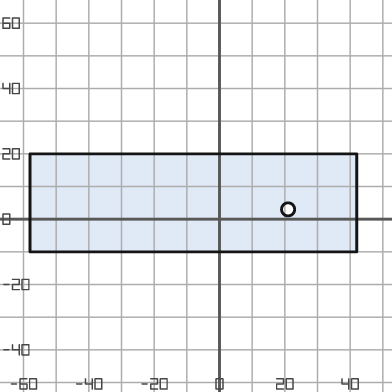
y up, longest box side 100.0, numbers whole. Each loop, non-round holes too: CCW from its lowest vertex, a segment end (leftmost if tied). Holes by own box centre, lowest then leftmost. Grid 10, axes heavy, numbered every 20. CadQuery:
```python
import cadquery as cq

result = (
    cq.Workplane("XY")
    .moveTo(-58.0, -10.0)
    .lineTo(42.0, -10.0)
    .lineTo(42.0, 20.0)
    .lineTo(-58.0, 20.0)
    .close()
    .moveTo(21.0, 3.0)
    .circle(2.0)
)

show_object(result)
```